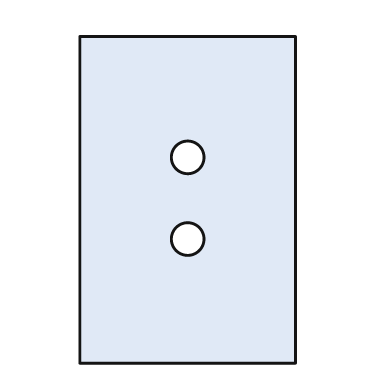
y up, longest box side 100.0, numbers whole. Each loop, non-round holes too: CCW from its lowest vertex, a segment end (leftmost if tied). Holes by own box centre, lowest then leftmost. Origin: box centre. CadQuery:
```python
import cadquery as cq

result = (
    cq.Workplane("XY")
    .moveTo(-33.0, -50.0)
    .lineTo(33.0, -50.0)
    .lineTo(33.0, 50.0)
    .lineTo(-33.0, 50.0)
    .close()
    .moveTo(0.0, -12.0)
    .circle(5.0)
    .moveTo(0.0, 13.0)
    .circle(5.0)
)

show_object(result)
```